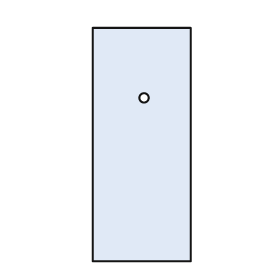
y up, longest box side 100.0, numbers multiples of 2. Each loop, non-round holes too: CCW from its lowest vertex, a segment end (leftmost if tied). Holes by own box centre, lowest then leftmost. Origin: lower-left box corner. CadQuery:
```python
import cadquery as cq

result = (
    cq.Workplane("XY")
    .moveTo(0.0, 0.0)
    .lineTo(42.0, 0.0)
    .lineTo(42.0, 100.0)
    .lineTo(0.0, 100.0)
    .close()
    .moveTo(22.0, 70.0)
    .circle(2.0)
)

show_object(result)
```